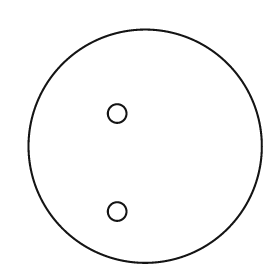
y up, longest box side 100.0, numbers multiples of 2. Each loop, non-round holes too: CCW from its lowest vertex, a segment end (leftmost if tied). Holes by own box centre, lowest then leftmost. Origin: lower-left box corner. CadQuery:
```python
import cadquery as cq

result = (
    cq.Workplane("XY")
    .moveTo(50.0, 50.0)
    .circle(50.0)
    .moveTo(38.0, 22.0)
    .circle(4.0)
    .moveTo(38.0, 64.0)
    .circle(4.0)
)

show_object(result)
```